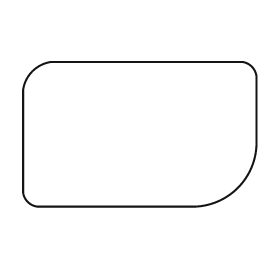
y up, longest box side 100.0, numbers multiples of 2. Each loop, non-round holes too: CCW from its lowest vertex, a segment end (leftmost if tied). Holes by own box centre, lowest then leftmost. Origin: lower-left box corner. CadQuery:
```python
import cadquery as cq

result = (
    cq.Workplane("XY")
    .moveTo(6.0, 0.0)
    .lineTo(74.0, 0.0)
    .threePointArc((92.0, 8.0), (100.0, 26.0))
    .lineTo(100.0, 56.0)
    .threePointArc((98.0, 60.0), (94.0, 62.0))
    .lineTo(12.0, 62.0)
    .threePointArc((4.0, 58.0), (0.0, 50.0))
    .lineTo(0.0, 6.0)
    .threePointArc((2.0, 2.0), (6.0, 0.0))
    .close()
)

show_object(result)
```